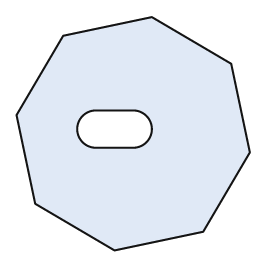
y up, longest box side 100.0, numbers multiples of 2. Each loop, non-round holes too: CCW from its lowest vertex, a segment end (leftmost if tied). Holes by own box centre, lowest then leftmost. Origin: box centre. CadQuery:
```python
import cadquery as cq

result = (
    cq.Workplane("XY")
    .moveTo(-8.0, -50.0)
    .lineTo(30.0, -42.0)
    .lineTo(50.0, -8.0)
    .lineTo(42.0, 30.0)
    .lineTo(8.0, 50.0)
    .lineTo(-30.0, 42.0)
    .lineTo(-50.0, 8.0)
    .lineTo(-42.0, -30.0)
    .close()
    .moveTo(-16.0, -6.0)
    .lineTo(0.0, -6.0)
    .threePointArc((8.0, 2.0), (0.0, 10.0))
    .lineTo(-16.0, 10.0)
    .threePointArc((-24.0, 2.0), (-16.0, -6.0))
    .close()
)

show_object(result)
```